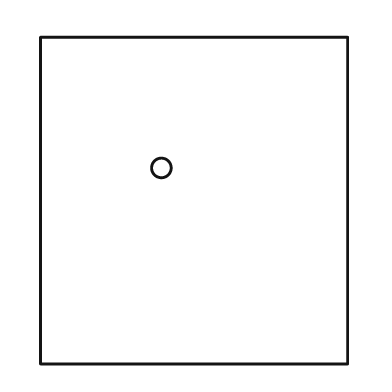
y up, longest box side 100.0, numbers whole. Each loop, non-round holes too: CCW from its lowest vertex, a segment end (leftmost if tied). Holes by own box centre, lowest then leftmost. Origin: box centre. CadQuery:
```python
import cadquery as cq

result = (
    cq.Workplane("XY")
    .moveTo(-47.0, -50.0)
    .lineTo(47.0, -50.0)
    .lineTo(47.0, 50.0)
    .lineTo(-47.0, 50.0)
    .close()
    .moveTo(-10.0, 10.0)
    .circle(3.0)
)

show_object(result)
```